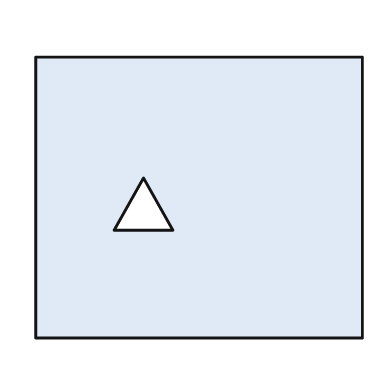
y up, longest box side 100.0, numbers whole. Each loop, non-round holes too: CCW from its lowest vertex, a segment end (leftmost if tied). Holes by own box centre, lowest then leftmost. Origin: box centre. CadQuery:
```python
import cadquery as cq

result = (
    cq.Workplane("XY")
    .moveTo(-50.0, -43.0)
    .lineTo(50.0, -43.0)
    .lineTo(50.0, 43.0)
    .lineTo(-50.0, 43.0)
    .close()
    .moveTo(-26.0, -10.0)
    .lineTo(-8.0, -10.0)
    .lineTo(-17.0, 6.0)
    .close()
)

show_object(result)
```